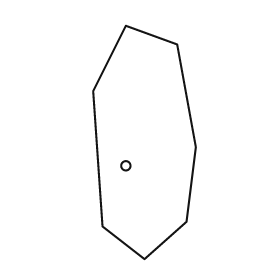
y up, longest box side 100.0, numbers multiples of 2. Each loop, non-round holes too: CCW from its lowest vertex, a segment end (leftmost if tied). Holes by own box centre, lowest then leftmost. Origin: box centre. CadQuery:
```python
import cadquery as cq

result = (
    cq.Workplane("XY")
    .moveTo(0.0, -50.0)
    .lineTo(18.0, -34.0)
    .lineTo(22.0, -2.0)
    .lineTo(14.0, 42.0)
    .lineTo(-8.0, 50.0)
    .lineTo(-22.0, 22.0)
    .lineTo(-18.0, -36.0)
    .close()
    .moveTo(-8.0, -10.0)
    .circle(2.0)
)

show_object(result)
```